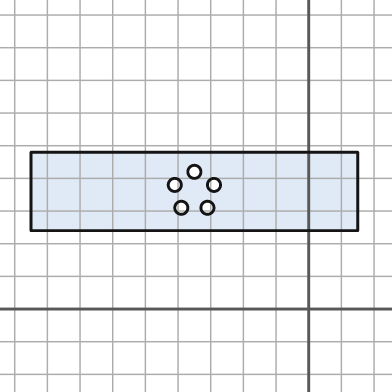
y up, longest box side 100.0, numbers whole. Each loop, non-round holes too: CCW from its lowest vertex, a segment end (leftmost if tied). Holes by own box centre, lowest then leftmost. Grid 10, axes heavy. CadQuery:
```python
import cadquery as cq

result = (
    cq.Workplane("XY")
    .moveTo(-85.0, 24.0)
    .lineTo(15.0, 24.0)
    .lineTo(15.0, 48.0)
    .lineTo(-85.0, 48.0)
    .close()
    .moveTo(-39.0, 31.0)
    .circle(2.0)
    .moveTo(-31.0, 31.0)
    .circle(2.0)
    .moveTo(-41.0, 38.0)
    .circle(2.0)
    .moveTo(-29.0, 38.0)
    .circle(2.0)
    .moveTo(-35.0, 42.0)
    .circle(2.0)
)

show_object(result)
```